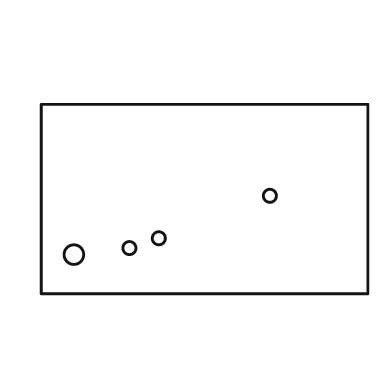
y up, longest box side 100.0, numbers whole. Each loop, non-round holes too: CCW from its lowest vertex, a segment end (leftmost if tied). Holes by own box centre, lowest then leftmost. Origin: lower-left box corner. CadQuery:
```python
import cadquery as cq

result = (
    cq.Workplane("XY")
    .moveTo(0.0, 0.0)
    .lineTo(100.0, 0.0)
    .lineTo(100.0, 58.0)
    .lineTo(0.0, 58.0)
    .close()
    .moveTo(10.0, 12.0)
    .circle(3.0)
    .moveTo(27.0, 14.0)
    .circle(2.0)
    .moveTo(36.0, 17.0)
    .circle(2.0)
    .moveTo(70.0, 30.0)
    .circle(2.0)
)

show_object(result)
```